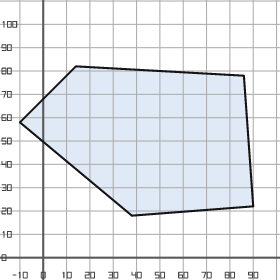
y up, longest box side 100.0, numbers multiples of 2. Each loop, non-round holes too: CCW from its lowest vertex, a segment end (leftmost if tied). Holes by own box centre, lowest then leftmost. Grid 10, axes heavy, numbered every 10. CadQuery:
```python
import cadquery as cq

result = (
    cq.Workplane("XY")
    .moveTo(38.0, 18.0)
    .lineTo(90.0, 22.0)
    .lineTo(86.0, 78.0)
    .lineTo(14.0, 82.0)
    .lineTo(-10.0, 58.0)
    .close()
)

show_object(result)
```